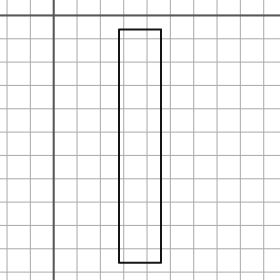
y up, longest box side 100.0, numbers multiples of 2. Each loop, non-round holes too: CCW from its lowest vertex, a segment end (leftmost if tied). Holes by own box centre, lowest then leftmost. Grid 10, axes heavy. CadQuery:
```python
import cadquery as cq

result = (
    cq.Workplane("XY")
    .moveTo(28.0, -106.0)
    .lineTo(46.0, -106.0)
    .lineTo(46.0, -6.0)
    .lineTo(28.0, -6.0)
    .close()
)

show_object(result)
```